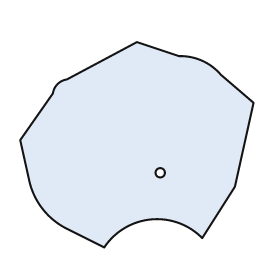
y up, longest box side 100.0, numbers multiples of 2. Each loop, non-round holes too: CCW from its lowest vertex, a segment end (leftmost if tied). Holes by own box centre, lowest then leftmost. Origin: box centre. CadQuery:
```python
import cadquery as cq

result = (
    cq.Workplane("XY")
    .moveTo(-14.0, -44.0)
    .threePointArc((6.0, -32.0), (28.0, -40.0))
    .lineTo(42.0, -18.0)
    .lineTo(50.0, 18.0)
    .lineTo(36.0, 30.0)
    .threePointArc((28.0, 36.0), (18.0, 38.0))
    .lineTo(0.0, 44.0)
    .lineTo(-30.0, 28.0)
    .threePointArc((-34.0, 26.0), (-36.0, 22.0))
    .lineTo(-50.0, 2.0)
    .lineTo(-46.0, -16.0)
    .threePointArc((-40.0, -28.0), (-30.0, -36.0))
    .close()
    .moveTo(10.0, -12.0)
    .circle(2.0)
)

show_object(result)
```